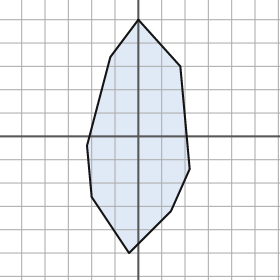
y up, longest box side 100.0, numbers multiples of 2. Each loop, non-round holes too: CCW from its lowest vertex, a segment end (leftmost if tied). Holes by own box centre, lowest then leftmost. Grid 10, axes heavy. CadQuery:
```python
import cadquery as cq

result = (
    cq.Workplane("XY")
    .moveTo(-4.0, -50.0)
    .lineTo(14.0, -32.0)
    .lineTo(22.0, -14.0)
    .lineTo(18.0, 30.0)
    .lineTo(0.0, 50.0)
    .lineTo(-12.0, 34.0)
    .lineTo(-22.0, -4.0)
    .lineTo(-20.0, -26.0)
    .close()
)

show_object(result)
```